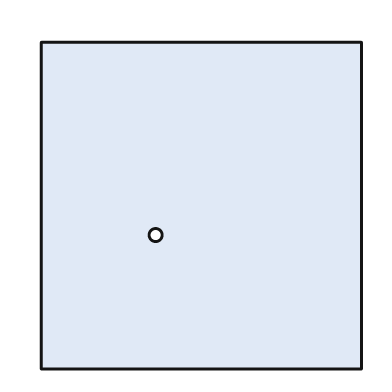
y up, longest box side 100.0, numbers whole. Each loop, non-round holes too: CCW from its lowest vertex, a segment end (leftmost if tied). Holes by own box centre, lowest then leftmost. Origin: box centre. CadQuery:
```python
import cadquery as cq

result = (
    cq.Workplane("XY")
    .moveTo(-49.0, -50.0)
    .lineTo(49.0, -50.0)
    .lineTo(49.0, 50.0)
    .lineTo(-49.0, 50.0)
    .close()
    .moveTo(-14.0, -9.0)
    .circle(2.0)
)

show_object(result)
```